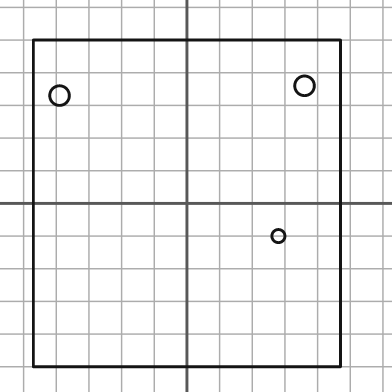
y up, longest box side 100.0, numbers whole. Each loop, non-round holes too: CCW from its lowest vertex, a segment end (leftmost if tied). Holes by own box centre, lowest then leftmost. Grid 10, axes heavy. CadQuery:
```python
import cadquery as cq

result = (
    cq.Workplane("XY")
    .moveTo(-47.0, -50.0)
    .lineTo(47.0, -50.0)
    .lineTo(47.0, 50.0)
    .lineTo(-47.0, 50.0)
    .close()
    .moveTo(28.0, -10.0)
    .circle(2.0)
    .moveTo(-39.0, 33.0)
    .circle(3.0)
    .moveTo(36.0, 36.0)
    .circle(3.0)
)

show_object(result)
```